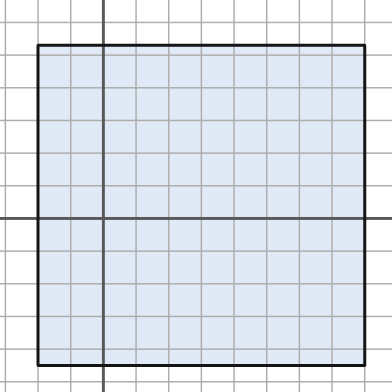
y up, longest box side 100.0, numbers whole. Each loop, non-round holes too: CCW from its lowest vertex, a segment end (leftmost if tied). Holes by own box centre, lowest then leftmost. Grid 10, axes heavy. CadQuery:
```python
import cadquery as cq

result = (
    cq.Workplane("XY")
    .moveTo(-20.0, -45.0)
    .lineTo(80.0, -45.0)
    .lineTo(80.0, 53.0)
    .lineTo(-20.0, 53.0)
    .close()
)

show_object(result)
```